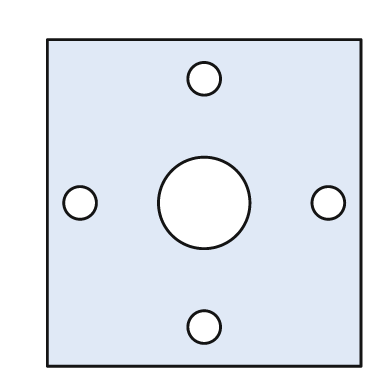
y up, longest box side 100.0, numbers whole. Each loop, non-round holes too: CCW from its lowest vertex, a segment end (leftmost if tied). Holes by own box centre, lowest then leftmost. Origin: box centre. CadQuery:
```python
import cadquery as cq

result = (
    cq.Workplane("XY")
    .moveTo(-48.0, -50.0)
    .lineTo(48.0, -50.0)
    .lineTo(48.0, 50.0)
    .lineTo(-48.0, 50.0)
    .close()
    .moveTo(0.0, -38.0)
    .circle(5.0)
    .moveTo(-38.0, 0.0)
    .circle(5.0)
    .moveTo(0.0, 0.0)
    .circle(14.0)
    .moveTo(38.0, 0.0)
    .circle(5.0)
    .moveTo(0.0, 38.0)
    .circle(5.0)
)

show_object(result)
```